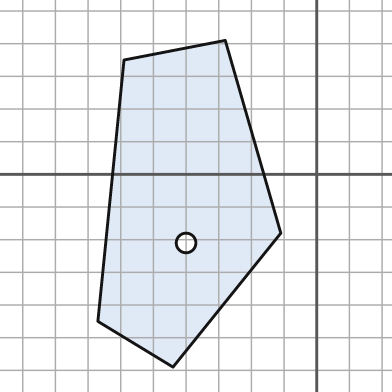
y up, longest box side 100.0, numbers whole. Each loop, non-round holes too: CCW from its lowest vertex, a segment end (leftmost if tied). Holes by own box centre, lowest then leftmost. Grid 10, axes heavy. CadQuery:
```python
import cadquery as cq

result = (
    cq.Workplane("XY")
    .moveTo(-44.0, -59.0)
    .lineTo(-11.0, -18.0)
    .lineTo(-28.0, 41.0)
    .lineTo(-59.0, 35.0)
    .lineTo(-67.0, -45.0)
    .close()
    .moveTo(-40.0, -21.0)
    .circle(3.0)
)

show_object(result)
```